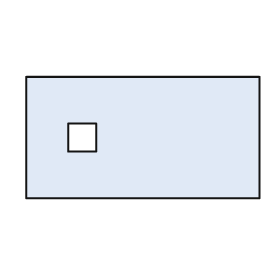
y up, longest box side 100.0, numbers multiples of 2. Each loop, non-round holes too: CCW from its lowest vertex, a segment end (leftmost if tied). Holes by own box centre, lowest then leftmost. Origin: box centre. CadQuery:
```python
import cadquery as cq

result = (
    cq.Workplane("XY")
    .moveTo(-50.0, -26.0)
    .lineTo(50.0, -26.0)
    .lineTo(50.0, 26.0)
    .lineTo(-50.0, 26.0)
    .close()
    .moveTo(-32.0, -6.0)
    .lineTo(-20.0, -6.0)
    .lineTo(-20.0, 6.0)
    .lineTo(-32.0, 6.0)
    .close()
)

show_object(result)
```